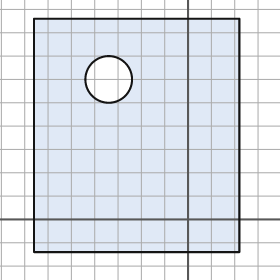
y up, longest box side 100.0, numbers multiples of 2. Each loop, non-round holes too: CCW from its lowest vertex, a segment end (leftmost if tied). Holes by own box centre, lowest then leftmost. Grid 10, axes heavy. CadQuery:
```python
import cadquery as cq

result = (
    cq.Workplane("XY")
    .moveTo(-66.0, -14.0)
    .lineTo(22.0, -14.0)
    .lineTo(22.0, 86.0)
    .lineTo(-66.0, 86.0)
    .close()
    .moveTo(-34.0, 60.0)
    .circle(10.0)
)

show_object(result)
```